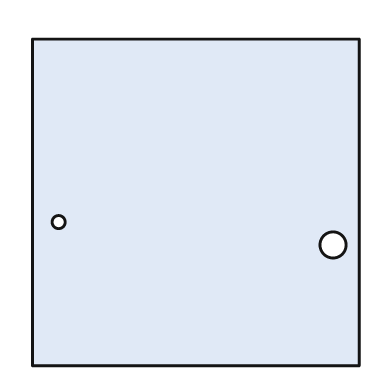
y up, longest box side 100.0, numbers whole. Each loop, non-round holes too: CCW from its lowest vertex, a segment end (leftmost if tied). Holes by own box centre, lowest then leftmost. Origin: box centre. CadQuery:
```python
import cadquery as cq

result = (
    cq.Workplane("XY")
    .moveTo(-50.0, -50.0)
    .lineTo(50.0, -50.0)
    .lineTo(50.0, 50.0)
    .lineTo(-50.0, 50.0)
    .close()
    .moveTo(42.0, -13.0)
    .circle(4.0)
    .moveTo(-42.0, -6.0)
    .circle(2.0)
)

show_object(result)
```